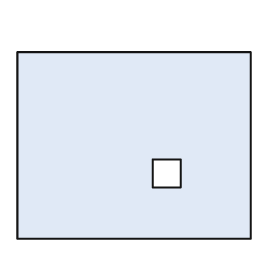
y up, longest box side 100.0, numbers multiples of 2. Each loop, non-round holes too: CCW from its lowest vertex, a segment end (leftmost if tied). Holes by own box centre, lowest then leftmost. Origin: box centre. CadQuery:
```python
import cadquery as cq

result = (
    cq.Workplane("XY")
    .moveTo(-50.0, -40.0)
    .lineTo(50.0, -40.0)
    .lineTo(50.0, 40.0)
    .lineTo(-50.0, 40.0)
    .close()
    .moveTo(8.0, -18.0)
    .lineTo(20.0, -18.0)
    .lineTo(20.0, -6.0)
    .lineTo(8.0, -6.0)
    .close()
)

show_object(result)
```